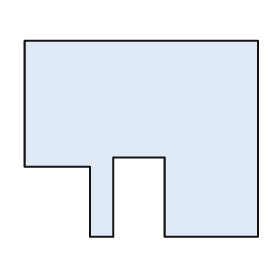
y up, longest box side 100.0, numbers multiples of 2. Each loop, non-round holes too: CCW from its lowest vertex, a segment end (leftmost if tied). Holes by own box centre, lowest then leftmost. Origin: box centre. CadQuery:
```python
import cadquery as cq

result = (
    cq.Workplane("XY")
    .moveTo(-22.0, -42.0)
    .lineTo(-12.0, -42.0)
    .lineTo(-12.0, -8.0)
    .lineTo(10.0, -8.0)
    .lineTo(10.0, -42.0)
    .lineTo(50.0, -42.0)
    .lineTo(50.0, 42.0)
    .lineTo(-50.0, 42.0)
    .lineTo(-50.0, -12.0)
    .lineTo(-22.0, -12.0)
    .close()
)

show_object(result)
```